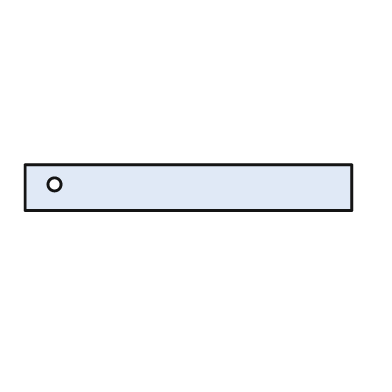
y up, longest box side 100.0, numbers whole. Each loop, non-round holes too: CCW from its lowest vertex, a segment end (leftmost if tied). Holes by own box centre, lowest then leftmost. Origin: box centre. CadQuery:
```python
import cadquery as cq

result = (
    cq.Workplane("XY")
    .moveTo(-50.0, -7.0)
    .lineTo(50.0, -7.0)
    .lineTo(50.0, 7.0)
    .lineTo(-50.0, 7.0)
    .close()
    .moveTo(-41.0, 1.0)
    .circle(2.0)
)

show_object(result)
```